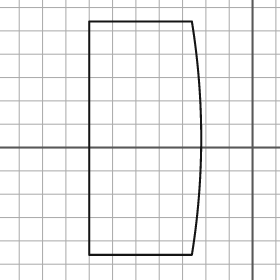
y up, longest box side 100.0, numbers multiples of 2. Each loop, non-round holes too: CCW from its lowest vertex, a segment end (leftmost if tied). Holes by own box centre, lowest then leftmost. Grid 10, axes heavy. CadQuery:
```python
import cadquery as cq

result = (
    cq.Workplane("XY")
    .moveTo(-70.0, -46.0)
    .lineTo(-26.0, -46.0)
    .threePointArc((-22.0, 4.0), (-26.0, 54.0))
    .lineTo(-70.0, 54.0)
    .close()
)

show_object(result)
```